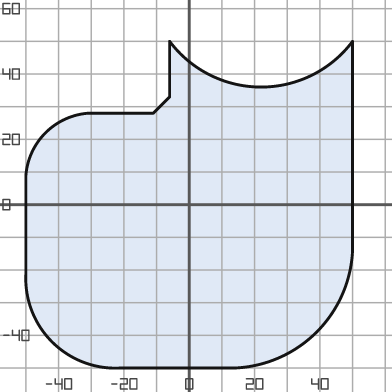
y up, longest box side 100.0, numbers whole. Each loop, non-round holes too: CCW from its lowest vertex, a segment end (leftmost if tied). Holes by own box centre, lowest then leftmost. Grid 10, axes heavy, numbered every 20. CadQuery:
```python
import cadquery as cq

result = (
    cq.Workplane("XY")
    .moveTo(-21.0, -50.0)
    .lineTo(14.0, -50.0)
    .threePointArc((39.0, -39.0), (50.0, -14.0))
    .lineTo(50.0, 50.0)
    .threePointArc((22.0, 36.0), (-6.0, 50.0))
    .lineTo(-6.0, 33.0)
    .lineTo(-11.0, 28.0)
    .lineTo(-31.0, 28.0)
    .threePointArc((-44.0, 22.0), (-50.0, 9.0))
    .lineTo(-50.0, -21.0)
    .threePointArc((-42.0, -42.0), (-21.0, -50.0))
    .close()
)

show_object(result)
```